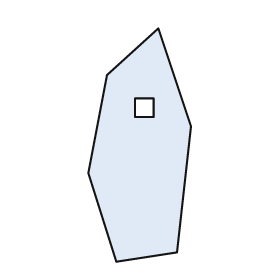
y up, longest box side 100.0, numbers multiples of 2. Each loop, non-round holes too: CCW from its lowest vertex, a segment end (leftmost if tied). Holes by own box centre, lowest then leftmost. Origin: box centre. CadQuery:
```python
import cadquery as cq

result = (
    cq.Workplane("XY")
    .moveTo(-10.0, -50.0)
    .lineTo(16.0, -46.0)
    .lineTo(22.0, 8.0)
    .lineTo(8.0, 50.0)
    .lineTo(-14.0, 30.0)
    .lineTo(-22.0, -12.0)
    .close()
    .moveTo(-2.0, 12.0)
    .lineTo(6.0, 12.0)
    .lineTo(6.0, 20.0)
    .lineTo(-2.0, 20.0)
    .close()
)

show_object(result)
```